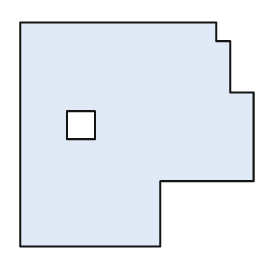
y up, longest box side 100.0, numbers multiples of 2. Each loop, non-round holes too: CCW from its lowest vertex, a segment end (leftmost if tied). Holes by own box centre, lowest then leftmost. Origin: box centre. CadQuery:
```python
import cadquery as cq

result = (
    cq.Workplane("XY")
    .moveTo(-50.0, -48.0)
    .lineTo(10.0, -48.0)
    .lineTo(10.0, -20.0)
    .lineTo(50.0, -20.0)
    .lineTo(50.0, 18.0)
    .lineTo(40.0, 18.0)
    .lineTo(40.0, 40.0)
    .lineTo(34.0, 40.0)
    .lineTo(34.0, 48.0)
    .lineTo(-50.0, 48.0)
    .close()
    .moveTo(-30.0, -2.0)
    .lineTo(-18.0, -2.0)
    .lineTo(-18.0, 10.0)
    .lineTo(-30.0, 10.0)
    .close()
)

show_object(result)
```